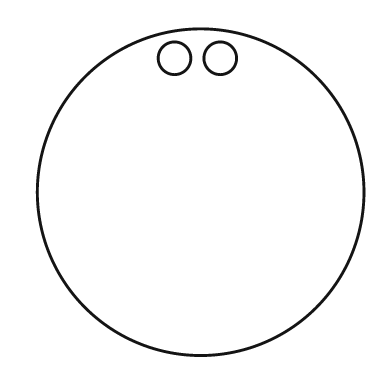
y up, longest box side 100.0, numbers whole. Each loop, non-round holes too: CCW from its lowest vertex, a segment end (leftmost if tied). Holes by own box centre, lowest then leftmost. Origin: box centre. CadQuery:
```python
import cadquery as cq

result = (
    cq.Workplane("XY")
    .moveTo(0.0, 0.0)
    .circle(50.0)
    .moveTo(-8.0, 41.0)
    .circle(5.0)
    .moveTo(6.0, 41.0)
    .circle(5.0)
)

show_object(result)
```